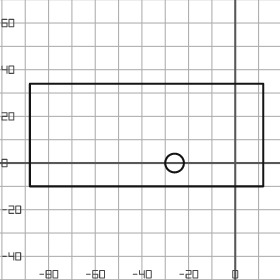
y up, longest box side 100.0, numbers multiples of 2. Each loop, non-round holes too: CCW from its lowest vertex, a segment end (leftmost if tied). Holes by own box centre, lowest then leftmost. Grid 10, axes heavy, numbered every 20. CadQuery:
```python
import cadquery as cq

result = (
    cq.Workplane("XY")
    .moveTo(-88.0, -10.0)
    .lineTo(12.0, -10.0)
    .lineTo(12.0, 34.0)
    .lineTo(-88.0, 34.0)
    .close()
    .moveTo(-26.0, 0.0)
    .circle(4.0)
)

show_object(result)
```